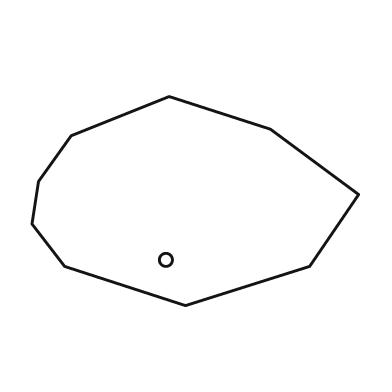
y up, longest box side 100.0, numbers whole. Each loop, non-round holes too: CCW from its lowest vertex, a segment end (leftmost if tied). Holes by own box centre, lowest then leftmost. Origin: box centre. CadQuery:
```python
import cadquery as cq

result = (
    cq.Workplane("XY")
    .moveTo(-3.0, -32.0)
    .lineTo(35.0, -20.0)
    .lineTo(50.0, 2.0)
    .lineTo(23.0, 22.0)
    .lineTo(-8.0, 32.0)
    .lineTo(-38.0, 20.0)
    .lineTo(-48.0, 6.0)
    .lineTo(-50.0, -7.0)
    .lineTo(-40.0, -20.0)
    .close()
    .moveTo(-9.0, -18.0)
    .circle(2.0)
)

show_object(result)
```